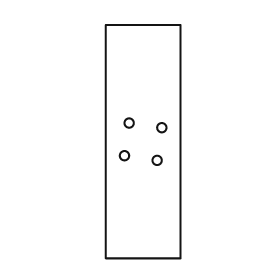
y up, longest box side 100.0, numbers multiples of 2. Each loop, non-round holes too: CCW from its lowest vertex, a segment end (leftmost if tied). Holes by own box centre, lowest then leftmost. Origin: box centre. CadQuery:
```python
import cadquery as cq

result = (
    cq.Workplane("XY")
    .moveTo(-16.0, -50.0)
    .lineTo(16.0, -50.0)
    .lineTo(16.0, 50.0)
    .lineTo(-16.0, 50.0)
    .close()
    .moveTo(6.0, -8.0)
    .circle(2.0)
    .moveTo(-8.0, -6.0)
    .circle(2.0)
    .moveTo(8.0, 6.0)
    .circle(2.0)
    .moveTo(-6.0, 8.0)
    .circle(2.0)
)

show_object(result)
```